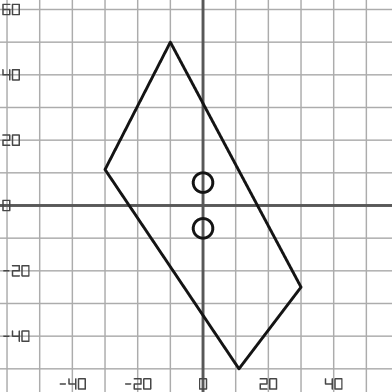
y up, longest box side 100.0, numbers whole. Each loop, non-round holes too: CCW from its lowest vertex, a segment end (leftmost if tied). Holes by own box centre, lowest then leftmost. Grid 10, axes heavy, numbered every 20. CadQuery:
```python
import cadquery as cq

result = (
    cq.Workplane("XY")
    .moveTo(11.0, -50.0)
    .lineTo(30.0, -25.0)
    .lineTo(-10.0, 50.0)
    .lineTo(-30.0, 11.0)
    .close()
    .moveTo(0.0, -7.0)
    .circle(3.0)
    .moveTo(0.0, 7.0)
    .circle(3.0)
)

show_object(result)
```